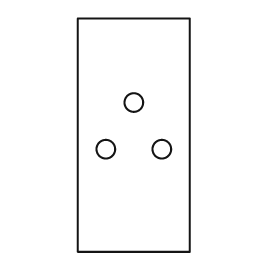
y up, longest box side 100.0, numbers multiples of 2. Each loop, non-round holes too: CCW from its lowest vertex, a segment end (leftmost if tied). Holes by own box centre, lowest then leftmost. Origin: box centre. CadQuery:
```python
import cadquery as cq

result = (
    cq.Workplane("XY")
    .moveTo(-24.0, -50.0)
    .lineTo(24.0, -50.0)
    .lineTo(24.0, 50.0)
    .lineTo(-24.0, 50.0)
    .close()
    .moveTo(-12.0, -6.0)
    .circle(4.0)
    .moveTo(12.0, -6.0)
    .circle(4.0)
    .moveTo(0.0, 14.0)
    .circle(4.0)
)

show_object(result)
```